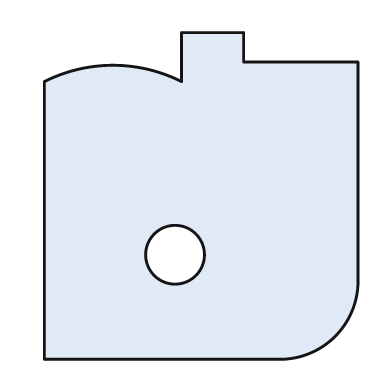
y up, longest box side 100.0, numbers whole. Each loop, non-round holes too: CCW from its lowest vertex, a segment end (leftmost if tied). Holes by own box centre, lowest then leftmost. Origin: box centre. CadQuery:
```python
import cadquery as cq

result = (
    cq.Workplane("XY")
    .moveTo(-48.0, -50.0)
    .lineTo(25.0, -50.0)
    .threePointArc((41.0, -43.0), (48.0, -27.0))
    .lineTo(48.0, 41.0)
    .lineTo(13.0, 41.0)
    .lineTo(13.0, 50.0)
    .lineTo(-6.0, 50.0)
    .lineTo(-6.0, 35.0)
    .threePointArc((-27.0, 40.0), (-48.0, 35.0))
    .close()
    .moveTo(-8.0, -18.0)
    .circle(9.0)
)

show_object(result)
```